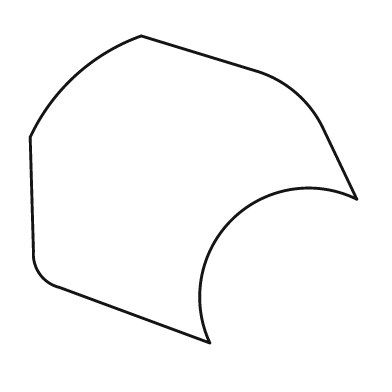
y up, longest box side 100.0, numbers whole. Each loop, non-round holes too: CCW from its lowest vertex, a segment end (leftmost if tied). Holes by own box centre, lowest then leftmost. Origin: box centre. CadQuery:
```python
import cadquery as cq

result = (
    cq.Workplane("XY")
    .moveTo(5.0, -47.0)
    .threePointArc((12.0, -9.0), (50.0, -3.0))
    .lineTo(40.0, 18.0)
    .threePointArc((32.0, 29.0), (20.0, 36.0))
    .lineTo(-16.0, 47.0)
    .threePointArc((-36.0, 35.0), (-50.0, 16.0))
    .lineTo(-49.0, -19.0)
    .threePointArc((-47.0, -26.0), (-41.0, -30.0))
    .close()
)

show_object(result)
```